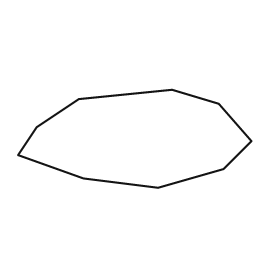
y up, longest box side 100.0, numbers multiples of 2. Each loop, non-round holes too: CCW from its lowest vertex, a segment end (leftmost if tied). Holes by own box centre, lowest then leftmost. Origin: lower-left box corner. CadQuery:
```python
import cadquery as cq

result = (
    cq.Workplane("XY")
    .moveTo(60.0, 0.0)
    .lineTo(88.0, 8.0)
    .lineTo(100.0, 20.0)
    .lineTo(86.0, 36.0)
    .lineTo(66.0, 42.0)
    .lineTo(26.0, 38.0)
    .lineTo(8.0, 26.0)
    .lineTo(0.0, 14.0)
    .lineTo(28.0, 4.0)
    .close()
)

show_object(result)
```